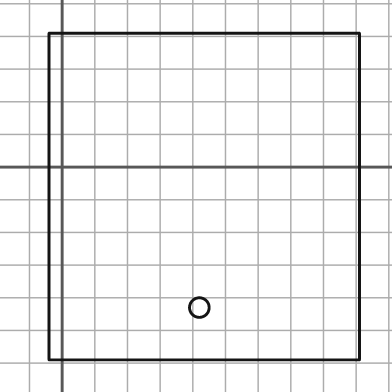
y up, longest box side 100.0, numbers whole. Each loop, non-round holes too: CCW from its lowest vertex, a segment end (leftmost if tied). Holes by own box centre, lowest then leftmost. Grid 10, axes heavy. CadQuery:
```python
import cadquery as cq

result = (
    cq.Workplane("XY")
    .moveTo(-4.0, -59.0)
    .lineTo(91.0, -59.0)
    .lineTo(91.0, 41.0)
    .lineTo(-4.0, 41.0)
    .close()
    .moveTo(42.0, -43.0)
    .circle(3.0)
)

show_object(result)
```